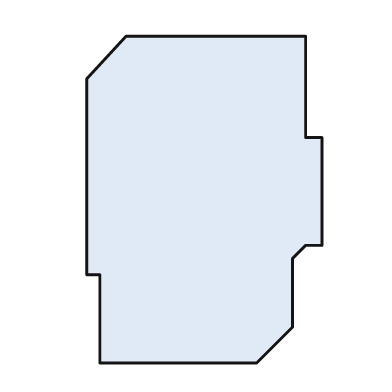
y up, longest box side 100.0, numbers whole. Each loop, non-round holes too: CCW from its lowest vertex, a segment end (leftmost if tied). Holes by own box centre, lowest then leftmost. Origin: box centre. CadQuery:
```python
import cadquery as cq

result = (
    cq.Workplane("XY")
    .moveTo(-32.0, -50.0)
    .lineTo(16.0, -50.0)
    .lineTo(27.0, -39.0)
    .lineTo(27.0, -18.0)
    .lineTo(31.0, -14.0)
    .lineTo(36.0, -14.0)
    .lineTo(36.0, 19.0)
    .lineTo(31.0, 19.0)
    .lineTo(31.0, 50.0)
    .lineTo(-24.0, 50.0)
    .lineTo(-36.0, 37.0)
    .lineTo(-36.0, -23.0)
    .lineTo(-32.0, -23.0)
    .close()
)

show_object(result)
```